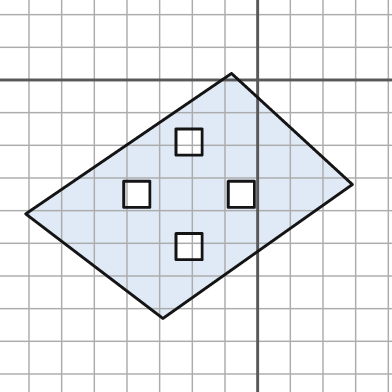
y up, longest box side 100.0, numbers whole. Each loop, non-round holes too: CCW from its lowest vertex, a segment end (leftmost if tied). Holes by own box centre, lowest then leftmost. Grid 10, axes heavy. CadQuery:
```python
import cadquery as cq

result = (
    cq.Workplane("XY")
    .moveTo(-29.0, -73.0)
    .lineTo(29.0, -32.0)
    .lineTo(-8.0, 2.0)
    .lineTo(-71.0, -41.0)
    .close()
    .moveTo(-25.0, -55.0)
    .lineTo(-17.0, -55.0)
    .lineTo(-17.0, -47.0)
    .lineTo(-25.0, -47.0)
    .close()
    .moveTo(-41.0, -39.0)
    .lineTo(-33.0, -39.0)
    .lineTo(-33.0, -31.0)
    .lineTo(-41.0, -31.0)
    .close()
    .moveTo(-9.0, -39.0)
    .lineTo(-1.0, -39.0)
    .lineTo(-1.0, -31.0)
    .lineTo(-9.0, -31.0)
    .close()
    .moveTo(-25.0, -23.0)
    .lineTo(-17.0, -23.0)
    .lineTo(-17.0, -15.0)
    .lineTo(-25.0, -15.0)
    .close()
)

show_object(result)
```